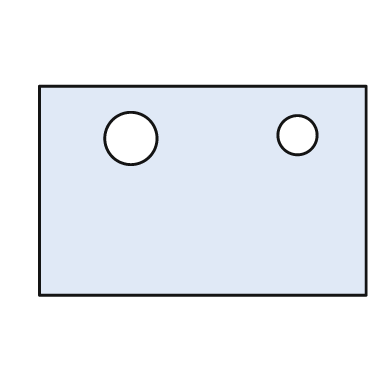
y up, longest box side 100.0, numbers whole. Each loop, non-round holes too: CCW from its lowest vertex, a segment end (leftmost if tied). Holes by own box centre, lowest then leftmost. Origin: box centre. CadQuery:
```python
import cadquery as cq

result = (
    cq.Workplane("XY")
    .moveTo(-50.0, -32.0)
    .lineTo(50.0, -32.0)
    .lineTo(50.0, 32.0)
    .lineTo(-50.0, 32.0)
    .close()
    .moveTo(-22.0, 16.0)
    .circle(8.0)
    .moveTo(29.0, 17.0)
    .circle(6.0)
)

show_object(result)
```